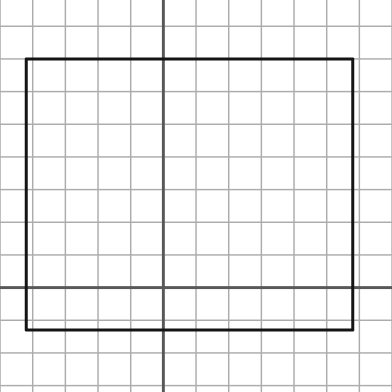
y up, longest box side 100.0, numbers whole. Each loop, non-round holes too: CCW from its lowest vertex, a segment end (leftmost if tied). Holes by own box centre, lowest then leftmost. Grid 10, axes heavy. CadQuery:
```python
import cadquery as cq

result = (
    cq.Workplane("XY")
    .moveTo(-42.0, -13.0)
    .lineTo(58.0, -13.0)
    .lineTo(58.0, 70.0)
    .lineTo(-42.0, 70.0)
    .close()
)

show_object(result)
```